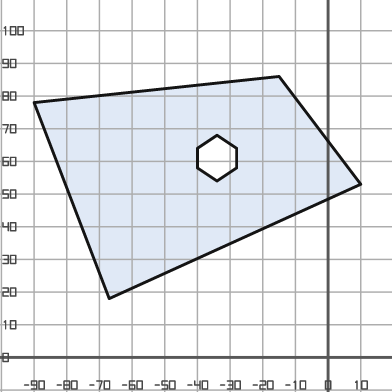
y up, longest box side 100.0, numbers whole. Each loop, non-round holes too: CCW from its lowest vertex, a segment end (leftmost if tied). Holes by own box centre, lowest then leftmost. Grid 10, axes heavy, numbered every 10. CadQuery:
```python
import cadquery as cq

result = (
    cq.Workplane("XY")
    .moveTo(-67.0, 18.0)
    .lineTo(10.0, 53.0)
    .lineTo(-15.0, 86.0)
    .lineTo(-90.0, 78.0)
    .close()
    .moveTo(-34.0, 54.0)
    .lineTo(-28.0, 58.0)
    .lineTo(-28.0, 64.0)
    .lineTo(-34.0, 68.0)
    .lineTo(-40.0, 64.0)
    .lineTo(-40.0, 58.0)
    .close()
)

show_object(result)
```